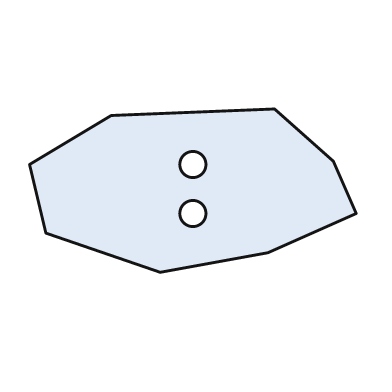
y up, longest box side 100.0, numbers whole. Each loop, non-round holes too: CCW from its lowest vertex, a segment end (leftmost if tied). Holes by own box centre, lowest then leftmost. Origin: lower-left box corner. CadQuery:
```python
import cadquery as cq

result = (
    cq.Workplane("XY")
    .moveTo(40.0, 0.0)
    .lineTo(73.0, 6.0)
    .lineTo(100.0, 18.0)
    .lineTo(93.0, 34.0)
    .lineTo(75.0, 50.0)
    .lineTo(25.0, 48.0)
    .lineTo(0.0, 33.0)
    .lineTo(5.0, 12.0)
    .close()
    .moveTo(50.0, 18.0)
    .circle(4.0)
    .moveTo(50.0, 33.0)
    .circle(4.0)
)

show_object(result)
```